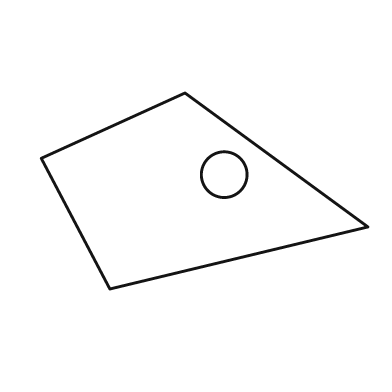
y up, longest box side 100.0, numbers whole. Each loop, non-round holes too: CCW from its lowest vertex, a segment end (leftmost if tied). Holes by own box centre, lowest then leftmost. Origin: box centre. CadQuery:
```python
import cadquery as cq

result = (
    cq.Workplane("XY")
    .moveTo(-29.0, -30.0)
    .lineTo(50.0, -11.0)
    .lineTo(-6.0, 30.0)
    .lineTo(-50.0, 10.0)
    .close()
    .moveTo(6.0, 5.0)
    .circle(7.0)
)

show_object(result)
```